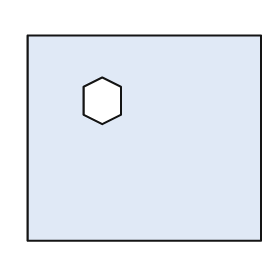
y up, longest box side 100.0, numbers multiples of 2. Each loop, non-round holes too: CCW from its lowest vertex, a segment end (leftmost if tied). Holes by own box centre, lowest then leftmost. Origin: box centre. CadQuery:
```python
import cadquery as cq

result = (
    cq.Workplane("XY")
    .moveTo(-50.0, -44.0)
    .lineTo(50.0, -44.0)
    .lineTo(50.0, 44.0)
    .lineTo(-50.0, 44.0)
    .close()
    .moveTo(-18.0, 6.0)
    .lineTo(-10.0, 10.0)
    .lineTo(-10.0, 22.0)
    .lineTo(-18.0, 26.0)
    .lineTo(-26.0, 22.0)
    .lineTo(-26.0, 10.0)
    .close()
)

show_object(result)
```